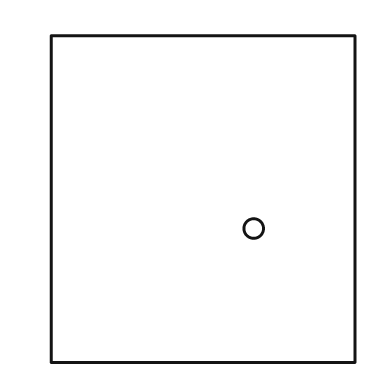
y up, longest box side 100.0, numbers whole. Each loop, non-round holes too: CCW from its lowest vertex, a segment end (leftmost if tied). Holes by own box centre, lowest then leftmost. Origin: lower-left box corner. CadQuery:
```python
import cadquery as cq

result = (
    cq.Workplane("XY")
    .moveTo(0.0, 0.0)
    .lineTo(93.0, 0.0)
    .lineTo(93.0, 100.0)
    .lineTo(0.0, 100.0)
    .close()
    .moveTo(62.0, 41.0)
    .circle(3.0)
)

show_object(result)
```